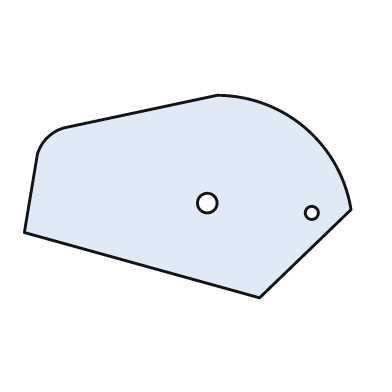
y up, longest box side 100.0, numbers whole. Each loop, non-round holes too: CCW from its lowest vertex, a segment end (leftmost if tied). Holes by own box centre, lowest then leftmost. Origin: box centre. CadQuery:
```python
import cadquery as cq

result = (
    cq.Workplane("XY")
    .moveTo(22.0, -31.0)
    .lineTo(50.0, -4.0)
    .threePointArc((36.0, 21.0), (9.0, 31.0))
    .lineTo(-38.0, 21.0)
    .threePointArc((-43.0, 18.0), (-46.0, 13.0))
    .lineTo(-50.0, -11.0)
    .close()
    .moveTo(38.0, -5.0)
    .circle(2.0)
    .moveTo(6.0, -2.0)
    .circle(3.0)
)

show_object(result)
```